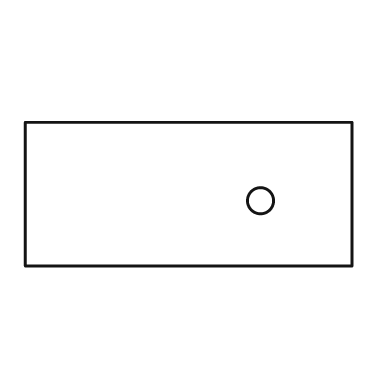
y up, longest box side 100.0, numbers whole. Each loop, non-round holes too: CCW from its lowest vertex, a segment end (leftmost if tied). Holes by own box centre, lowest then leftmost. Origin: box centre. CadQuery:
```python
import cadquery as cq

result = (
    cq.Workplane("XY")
    .moveTo(-50.0, -22.0)
    .lineTo(50.0, -22.0)
    .lineTo(50.0, 22.0)
    .lineTo(-50.0, 22.0)
    .close()
    .moveTo(22.0, -2.0)
    .circle(4.0)
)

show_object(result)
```